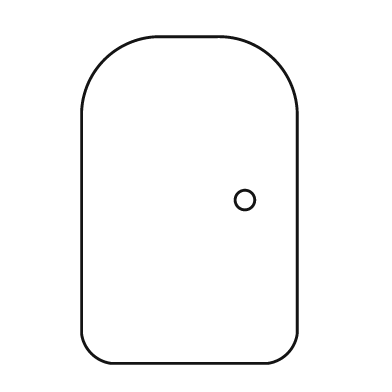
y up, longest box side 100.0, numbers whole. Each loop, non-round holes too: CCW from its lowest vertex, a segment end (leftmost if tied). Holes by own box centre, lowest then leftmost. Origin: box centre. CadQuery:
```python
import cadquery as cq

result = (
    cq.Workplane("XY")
    .moveTo(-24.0, -50.0)
    .lineTo(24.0, -50.0)
    .threePointArc((30.0, -47.0), (33.0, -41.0))
    .lineTo(33.0, 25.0)
    .threePointArc((26.0, 43.0), (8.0, 50.0))
    .lineTo(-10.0, 50.0)
    .threePointArc((-26.0, 43.0), (-33.0, 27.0))
    .lineTo(-33.0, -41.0)
    .threePointArc((-30.0, -47.0), (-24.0, -50.0))
    .close()
    .moveTo(17.0, 0.0)
    .circle(3.0)
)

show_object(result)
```